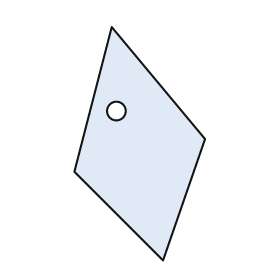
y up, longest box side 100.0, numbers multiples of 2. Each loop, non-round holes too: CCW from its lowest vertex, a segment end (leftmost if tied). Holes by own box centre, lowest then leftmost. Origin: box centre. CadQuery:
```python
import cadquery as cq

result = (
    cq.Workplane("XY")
    .moveTo(10.0, -50.0)
    .lineTo(28.0, 2.0)
    .lineTo(-12.0, 50.0)
    .lineTo(-28.0, -12.0)
    .close()
    .moveTo(-10.0, 14.0)
    .circle(4.0)
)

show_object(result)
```